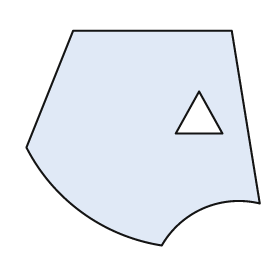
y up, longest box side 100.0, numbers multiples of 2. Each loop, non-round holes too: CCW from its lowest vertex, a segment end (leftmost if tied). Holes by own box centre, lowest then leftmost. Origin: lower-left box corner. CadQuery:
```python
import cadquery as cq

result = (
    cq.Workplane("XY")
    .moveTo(58.0, 0.0)
    .threePointArc((76.0, 16.0), (100.0, 18.0))
    .lineTo(88.0, 92.0)
    .lineTo(20.0, 92.0)
    .lineTo(0.0, 42.0)
    .threePointArc((24.0, 14.0), (58.0, 0.0))
    .close()
    .moveTo(64.0, 48.0)
    .lineTo(84.0, 48.0)
    .lineTo(74.0, 66.0)
    .close()
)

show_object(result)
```